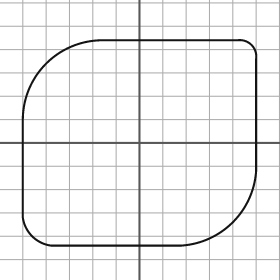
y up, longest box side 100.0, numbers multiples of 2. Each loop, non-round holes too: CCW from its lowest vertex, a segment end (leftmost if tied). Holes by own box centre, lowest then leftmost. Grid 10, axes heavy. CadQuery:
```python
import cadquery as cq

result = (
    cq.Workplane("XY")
    .moveTo(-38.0, -44.0)
    .lineTo(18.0, -44.0)
    .threePointArc((40.0, -34.0), (50.0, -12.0))
    .lineTo(50.0, 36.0)
    .threePointArc((48.0, 42.0), (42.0, 44.0))
    .lineTo(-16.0, 44.0)
    .threePointArc((-40.0, 34.0), (-50.0, 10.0))
    .lineTo(-50.0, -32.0)
    .threePointArc((-46.0, -40.0), (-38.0, -44.0))
    .close()
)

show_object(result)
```